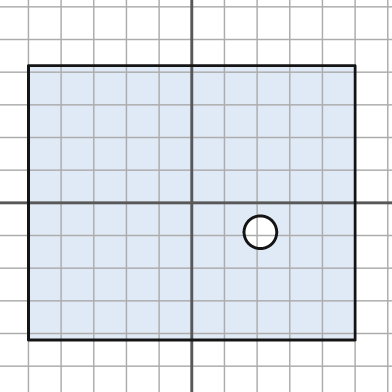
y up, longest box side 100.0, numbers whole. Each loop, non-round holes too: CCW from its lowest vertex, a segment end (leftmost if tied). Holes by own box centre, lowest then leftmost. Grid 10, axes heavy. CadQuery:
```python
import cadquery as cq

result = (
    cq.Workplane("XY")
    .moveTo(-50.0, -42.0)
    .lineTo(50.0, -42.0)
    .lineTo(50.0, 42.0)
    .lineTo(-50.0, 42.0)
    .close()
    .moveTo(21.0, -9.0)
    .circle(5.0)
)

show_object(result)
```